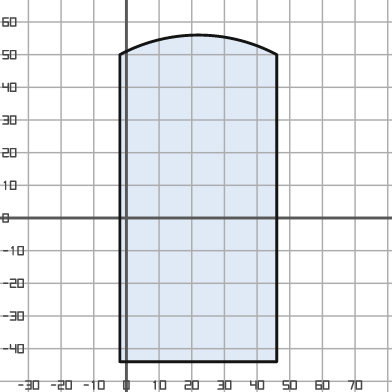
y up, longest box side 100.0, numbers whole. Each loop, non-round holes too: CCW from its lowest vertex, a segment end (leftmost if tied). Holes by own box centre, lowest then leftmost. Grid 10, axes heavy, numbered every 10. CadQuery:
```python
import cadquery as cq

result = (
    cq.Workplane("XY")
    .moveTo(-2.0, -44.0)
    .lineTo(46.0, -44.0)
    .lineTo(46.0, 50.0)
    .threePointArc((22.0, 56.0), (-2.0, 50.0))
    .close()
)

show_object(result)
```